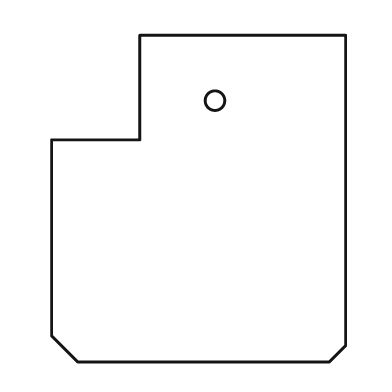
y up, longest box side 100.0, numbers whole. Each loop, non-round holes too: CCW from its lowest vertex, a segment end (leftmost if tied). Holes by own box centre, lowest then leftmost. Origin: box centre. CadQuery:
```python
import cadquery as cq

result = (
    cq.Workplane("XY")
    .moveTo(-37.0, -50.0)
    .lineTo(40.0, -50.0)
    .lineTo(45.0, -45.0)
    .lineTo(45.0, 50.0)
    .lineTo(-18.0, 50.0)
    .lineTo(-18.0, 18.0)
    .lineTo(-45.0, 18.0)
    .lineTo(-45.0, -42.0)
    .close()
    .moveTo(5.0, 30.0)
    .circle(3.0)
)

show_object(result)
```